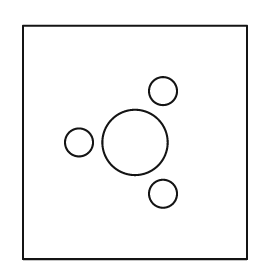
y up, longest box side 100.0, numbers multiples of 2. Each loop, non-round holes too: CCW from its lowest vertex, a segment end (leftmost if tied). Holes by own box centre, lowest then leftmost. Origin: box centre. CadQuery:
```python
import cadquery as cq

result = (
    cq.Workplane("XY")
    .moveTo(-48.0, -50.0)
    .lineTo(48.0, -50.0)
    .lineTo(48.0, 50.0)
    .lineTo(-48.0, 50.0)
    .close()
    .moveTo(12.0, -22.0)
    .circle(6.0)
    .moveTo(-24.0, 0.0)
    .circle(6.0)
    .moveTo(0.0, 0.0)
    .circle(14.0)
    .moveTo(12.0, 22.0)
    .circle(6.0)
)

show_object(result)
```